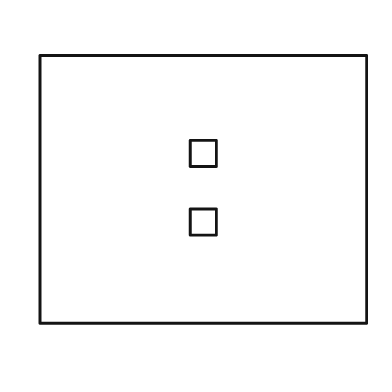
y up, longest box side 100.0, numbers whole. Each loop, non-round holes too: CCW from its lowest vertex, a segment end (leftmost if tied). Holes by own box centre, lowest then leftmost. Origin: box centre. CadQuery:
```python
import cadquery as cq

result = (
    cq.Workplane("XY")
    .moveTo(-50.0, -41.0)
    .lineTo(50.0, -41.0)
    .lineTo(50.0, 41.0)
    .lineTo(-50.0, 41.0)
    .close()
    .moveTo(-4.0, -14.0)
    .lineTo(4.0, -14.0)
    .lineTo(4.0, -6.0)
    .lineTo(-4.0, -6.0)
    .close()
    .moveTo(-4.0, 7.0)
    .lineTo(4.0, 7.0)
    .lineTo(4.0, 15.0)
    .lineTo(-4.0, 15.0)
    .close()
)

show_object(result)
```